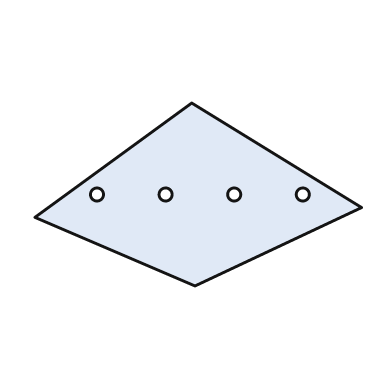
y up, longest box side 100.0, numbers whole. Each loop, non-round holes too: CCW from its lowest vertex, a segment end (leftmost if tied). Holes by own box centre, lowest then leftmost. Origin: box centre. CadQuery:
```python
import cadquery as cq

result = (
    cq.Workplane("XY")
    .moveTo(-1.0, -28.0)
    .lineTo(50.0, -4.0)
    .lineTo(-2.0, 28.0)
    .lineTo(-50.0, -7.0)
    .close()
    .moveTo(-31.0, 0.0)
    .circle(2.0)
    .moveTo(-10.0, 0.0)
    .circle(2.0)
    .moveTo(11.0, 0.0)
    .circle(2.0)
    .moveTo(32.0, 0.0)
    .circle(2.0)
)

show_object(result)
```